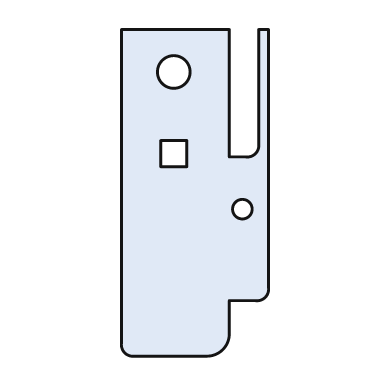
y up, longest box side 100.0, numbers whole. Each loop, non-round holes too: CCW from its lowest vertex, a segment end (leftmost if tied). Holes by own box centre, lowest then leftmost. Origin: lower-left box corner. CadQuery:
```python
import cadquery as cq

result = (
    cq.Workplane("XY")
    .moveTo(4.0, 0.0)
    .lineTo(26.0, 0.0)
    .threePointArc((31.0, 2.0), (33.0, 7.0))
    .lineTo(33.0, 17.0)
    .lineTo(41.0, 17.0)
    .threePointArc((44.0, 18.0), (45.0, 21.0))
    .lineTo(45.0, 100.0)
    .lineTo(42.0, 100.0)
    .lineTo(42.0, 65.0)
    .threePointArc((41.0, 62.0), (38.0, 61.0))
    .lineTo(33.0, 61.0)
    .lineTo(33.0, 100.0)
    .lineTo(0.0, 100.0)
    .lineTo(0.0, 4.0)
    .threePointArc((1.0, 1.0), (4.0, 0.0))
    .close()
    .moveTo(37.0, 45.0)
    .circle(3.0)
    .moveTo(12.0, 58.0)
    .lineTo(20.0, 58.0)
    .lineTo(20.0, 66.0)
    .lineTo(12.0, 66.0)
    .close()
    .moveTo(16.0, 87.0)
    .circle(5.0)
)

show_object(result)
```